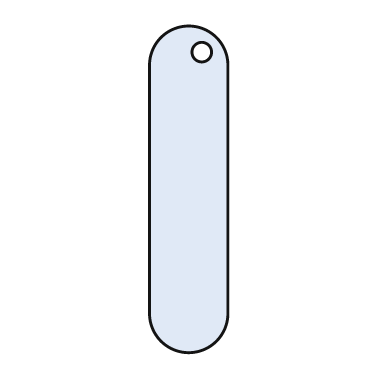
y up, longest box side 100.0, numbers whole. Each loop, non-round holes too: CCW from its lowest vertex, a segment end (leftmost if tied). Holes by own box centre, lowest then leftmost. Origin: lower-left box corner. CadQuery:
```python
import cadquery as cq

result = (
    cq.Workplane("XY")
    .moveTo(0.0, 12.0)
    .threePointArc((12.0, 0.0), (24.0, 12.0))
    .lineTo(24.0, 88.0)
    .threePointArc((12.0, 100.0), (0.0, 88.0))
    .close()
    .moveTo(16.0, 92.0)
    .circle(3.0)
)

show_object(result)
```